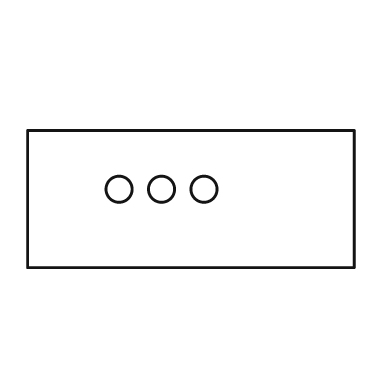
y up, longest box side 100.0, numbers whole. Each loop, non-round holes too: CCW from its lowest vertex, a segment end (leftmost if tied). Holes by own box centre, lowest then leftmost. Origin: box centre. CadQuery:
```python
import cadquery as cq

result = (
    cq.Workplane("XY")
    .moveTo(-50.0, -21.0)
    .lineTo(50.0, -21.0)
    .lineTo(50.0, 21.0)
    .lineTo(-50.0, 21.0)
    .close()
    .moveTo(-22.0, 3.0)
    .circle(4.0)
    .moveTo(-9.0, 3.0)
    .circle(4.0)
    .moveTo(4.0, 3.0)
    .circle(4.0)
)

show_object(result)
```